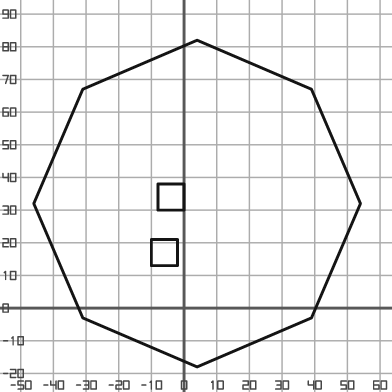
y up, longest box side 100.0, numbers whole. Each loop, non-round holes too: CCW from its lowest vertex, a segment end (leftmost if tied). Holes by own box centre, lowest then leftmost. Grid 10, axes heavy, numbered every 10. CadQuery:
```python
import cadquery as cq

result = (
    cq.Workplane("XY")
    .moveTo(4.0, -18.0)
    .lineTo(39.0, -3.0)
    .lineTo(54.0, 32.0)
    .lineTo(39.0, 67.0)
    .lineTo(4.0, 82.0)
    .lineTo(-31.0, 67.0)
    .lineTo(-46.0, 32.0)
    .lineTo(-31.0, -3.0)
    .close()
    .moveTo(-10.0, 13.0)
    .lineTo(-2.0, 13.0)
    .lineTo(-2.0, 21.0)
    .lineTo(-10.0, 21.0)
    .close()
    .moveTo(-8.0, 30.0)
    .lineTo(0.0, 30.0)
    .lineTo(0.0, 38.0)
    .lineTo(-8.0, 38.0)
    .close()
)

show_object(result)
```